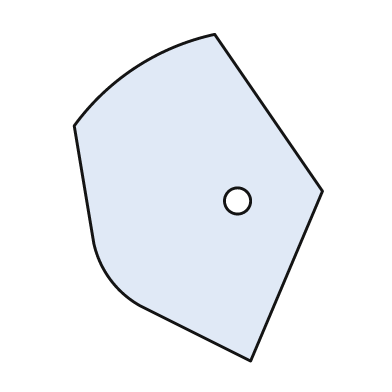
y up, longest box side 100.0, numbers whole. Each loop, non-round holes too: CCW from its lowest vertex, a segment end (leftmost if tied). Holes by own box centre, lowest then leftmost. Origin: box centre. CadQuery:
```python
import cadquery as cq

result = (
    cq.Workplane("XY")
    .moveTo(16.0, -50.0)
    .lineTo(38.0, 2.0)
    .lineTo(5.0, 50.0)
    .threePointArc((-19.0, 40.0), (-38.0, 22.0))
    .lineTo(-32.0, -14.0)
    .threePointArc((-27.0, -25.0), (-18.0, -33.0))
    .close()
    .moveTo(12.0, -1.0)
    .circle(4.0)
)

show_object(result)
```